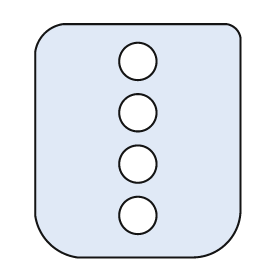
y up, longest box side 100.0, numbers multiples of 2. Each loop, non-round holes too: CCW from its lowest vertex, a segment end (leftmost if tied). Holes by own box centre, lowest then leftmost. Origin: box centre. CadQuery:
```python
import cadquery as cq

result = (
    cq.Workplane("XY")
    .moveTo(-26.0, -50.0)
    .lineTo(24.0, -50.0)
    .threePointArc((38.0, -44.0), (44.0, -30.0))
    .lineTo(44.0, 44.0)
    .threePointArc((42.0, 48.0), (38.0, 50.0))
    .lineTo(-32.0, 50.0)
    .threePointArc((-40.0, 46.0), (-44.0, 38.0))
    .lineTo(-44.0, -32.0)
    .threePointArc((-38.0, -44.0), (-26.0, -50.0))
    .close()
    .moveTo(0.0, -32.0)
    .circle(8.0)
    .moveTo(0.0, -10.0)
    .circle(8.0)
    .moveTo(0.0, 12.0)
    .circle(8.0)
    .moveTo(0.0, 34.0)
    .circle(8.0)
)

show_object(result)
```